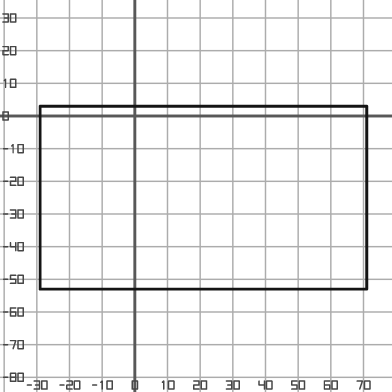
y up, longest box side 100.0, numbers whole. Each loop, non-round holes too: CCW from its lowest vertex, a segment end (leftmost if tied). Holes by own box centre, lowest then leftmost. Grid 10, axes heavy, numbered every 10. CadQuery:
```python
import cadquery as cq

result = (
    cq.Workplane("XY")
    .moveTo(-29.0, -53.0)
    .lineTo(71.0, -53.0)
    .lineTo(71.0, 3.0)
    .lineTo(-29.0, 3.0)
    .close()
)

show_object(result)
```